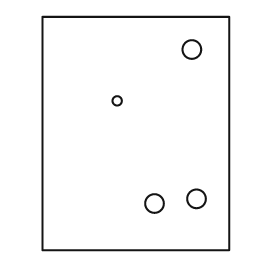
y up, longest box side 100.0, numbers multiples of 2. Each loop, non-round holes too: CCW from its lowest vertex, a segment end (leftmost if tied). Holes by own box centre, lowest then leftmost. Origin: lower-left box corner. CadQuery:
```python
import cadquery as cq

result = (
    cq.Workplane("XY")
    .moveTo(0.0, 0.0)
    .lineTo(80.0, 0.0)
    .lineTo(80.0, 100.0)
    .lineTo(0.0, 100.0)
    .close()
    .moveTo(48.0, 20.0)
    .circle(4.0)
    .moveTo(66.0, 22.0)
    .circle(4.0)
    .moveTo(32.0, 64.0)
    .circle(2.0)
    .moveTo(64.0, 86.0)
    .circle(4.0)
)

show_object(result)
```